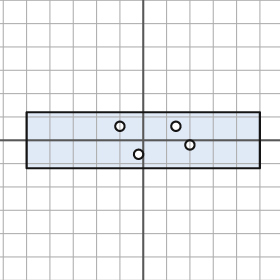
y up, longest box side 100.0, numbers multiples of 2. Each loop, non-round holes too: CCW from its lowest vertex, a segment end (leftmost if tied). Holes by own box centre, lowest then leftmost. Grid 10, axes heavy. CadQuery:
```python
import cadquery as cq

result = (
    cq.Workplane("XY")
    .moveTo(-50.0, -12.0)
    .lineTo(50.0, -12.0)
    .lineTo(50.0, 12.0)
    .lineTo(-50.0, 12.0)
    .close()
    .moveTo(-2.0, -6.0)
    .circle(2.0)
    .moveTo(20.0, -2.0)
    .circle(2.0)
    .moveTo(-10.0, 6.0)
    .circle(2.0)
    .moveTo(14.0, 6.0)
    .circle(2.0)
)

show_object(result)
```